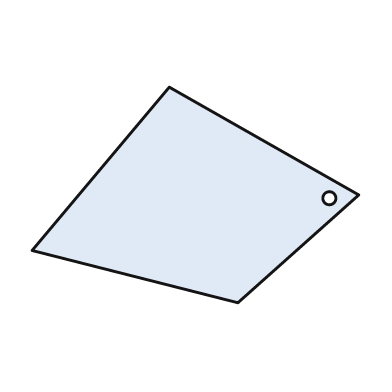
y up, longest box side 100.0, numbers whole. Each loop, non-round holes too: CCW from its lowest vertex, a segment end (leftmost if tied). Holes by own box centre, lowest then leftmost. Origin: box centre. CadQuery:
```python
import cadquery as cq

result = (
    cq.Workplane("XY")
    .moveTo(13.0, -33.0)
    .lineTo(50.0, 0.0)
    .lineTo(-8.0, 33.0)
    .lineTo(-50.0, -17.0)
    .close()
    .moveTo(41.0, -1.0)
    .circle(2.0)
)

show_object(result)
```